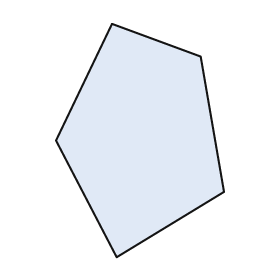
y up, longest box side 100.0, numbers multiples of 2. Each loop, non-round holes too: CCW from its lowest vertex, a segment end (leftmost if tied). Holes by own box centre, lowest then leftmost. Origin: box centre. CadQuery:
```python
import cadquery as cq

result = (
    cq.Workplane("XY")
    .moveTo(-10.0, -50.0)
    .lineTo(36.0, -22.0)
    .lineTo(26.0, 36.0)
    .lineTo(-12.0, 50.0)
    .lineTo(-36.0, 0.0)
    .close()
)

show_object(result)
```